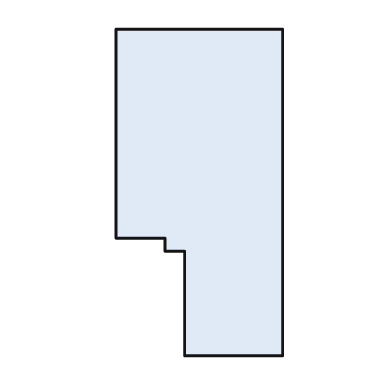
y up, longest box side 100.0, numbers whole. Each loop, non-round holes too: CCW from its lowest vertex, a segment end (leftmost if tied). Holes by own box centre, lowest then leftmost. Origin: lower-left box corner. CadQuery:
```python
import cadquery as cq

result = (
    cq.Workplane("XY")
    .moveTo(21.0, 0.0)
    .lineTo(51.0, 0.0)
    .lineTo(51.0, 100.0)
    .lineTo(0.0, 100.0)
    .lineTo(0.0, 36.0)
    .lineTo(15.0, 36.0)
    .lineTo(15.0, 32.0)
    .lineTo(21.0, 32.0)
    .close()
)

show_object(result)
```